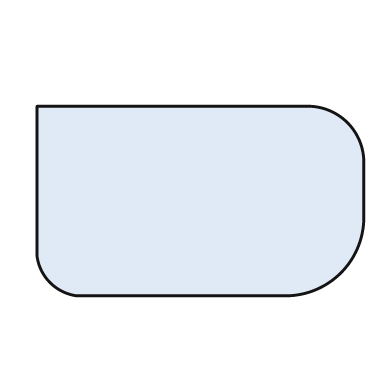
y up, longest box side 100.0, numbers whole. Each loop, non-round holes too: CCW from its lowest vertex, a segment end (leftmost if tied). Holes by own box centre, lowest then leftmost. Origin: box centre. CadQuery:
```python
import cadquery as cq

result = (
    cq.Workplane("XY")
    .moveTo(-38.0, -29.0)
    .lineTo(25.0, -29.0)
    .threePointArc((43.0, -22.0), (50.0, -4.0))
    .lineTo(50.0, 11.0)
    .threePointArc((45.0, 24.0), (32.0, 29.0))
    .lineTo(-50.0, 29.0)
    .lineTo(-50.0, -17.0)
    .threePointArc((-46.0, -25.0), (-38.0, -29.0))
    .close()
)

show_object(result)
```